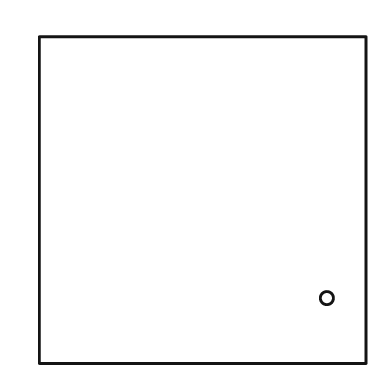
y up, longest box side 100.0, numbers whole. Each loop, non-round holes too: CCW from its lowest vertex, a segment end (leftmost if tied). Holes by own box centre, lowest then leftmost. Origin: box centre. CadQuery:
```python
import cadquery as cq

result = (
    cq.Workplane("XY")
    .moveTo(-50.0, -50.0)
    .lineTo(50.0, -50.0)
    .lineTo(50.0, 50.0)
    .lineTo(-50.0, 50.0)
    .close()
    .moveTo(38.0, -30.0)
    .circle(2.0)
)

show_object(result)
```